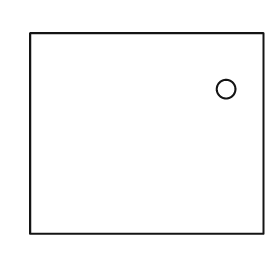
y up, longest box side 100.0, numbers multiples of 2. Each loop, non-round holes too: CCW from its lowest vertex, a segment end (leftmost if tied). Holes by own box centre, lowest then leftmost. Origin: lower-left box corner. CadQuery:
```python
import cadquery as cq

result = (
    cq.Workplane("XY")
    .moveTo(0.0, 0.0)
    .lineTo(100.0, 0.0)
    .lineTo(100.0, 86.0)
    .lineTo(0.0, 86.0)
    .close()
    .moveTo(84.0, 62.0)
    .circle(4.0)
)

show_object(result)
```